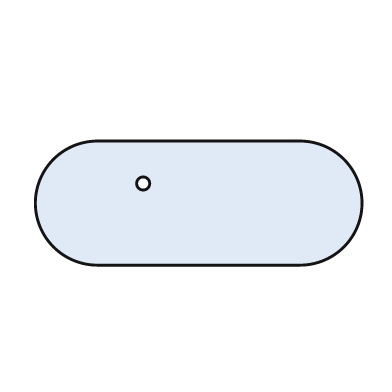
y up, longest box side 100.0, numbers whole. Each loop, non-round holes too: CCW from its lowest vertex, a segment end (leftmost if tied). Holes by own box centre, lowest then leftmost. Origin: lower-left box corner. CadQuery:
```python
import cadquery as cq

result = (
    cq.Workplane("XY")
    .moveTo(19.0, 0.0)
    .lineTo(81.0, 0.0)
    .threePointArc((100.0, 19.0), (81.0, 38.0))
    .lineTo(19.0, 38.0)
    .threePointArc((0.0, 19.0), (19.0, 0.0))
    .close()
    .moveTo(33.0, 25.0)
    .circle(2.0)
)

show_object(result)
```